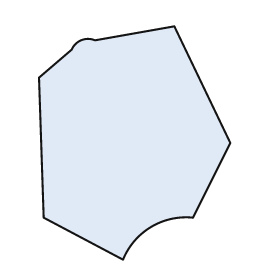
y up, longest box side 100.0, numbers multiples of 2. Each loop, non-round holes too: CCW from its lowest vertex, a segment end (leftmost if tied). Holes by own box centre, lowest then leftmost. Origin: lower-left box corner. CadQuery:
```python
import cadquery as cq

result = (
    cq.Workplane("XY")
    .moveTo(36.0, 0.0)
    .threePointArc((48.0, 14.0), (66.0, 18.0))
    .lineTo(82.0, 50.0)
    .lineTo(58.0, 100.0)
    .lineTo(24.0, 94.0)
    .threePointArc((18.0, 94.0), (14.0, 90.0))
    .lineTo(0.0, 78.0)
    .lineTo(2.0, 18.0)
    .close()
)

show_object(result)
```